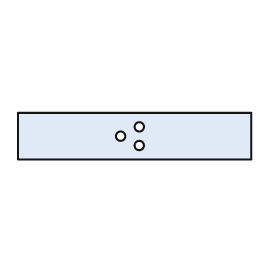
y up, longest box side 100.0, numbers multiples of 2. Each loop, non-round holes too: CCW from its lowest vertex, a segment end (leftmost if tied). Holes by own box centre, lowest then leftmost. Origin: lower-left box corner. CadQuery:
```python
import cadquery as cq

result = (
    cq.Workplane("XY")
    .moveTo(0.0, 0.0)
    .lineTo(100.0, 0.0)
    .lineTo(100.0, 20.0)
    .lineTo(0.0, 20.0)
    .close()
    .moveTo(52.0, 6.0)
    .circle(2.0)
    .moveTo(44.0, 10.0)
    .circle(2.0)
    .moveTo(52.0, 14.0)
    .circle(2.0)
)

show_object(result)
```